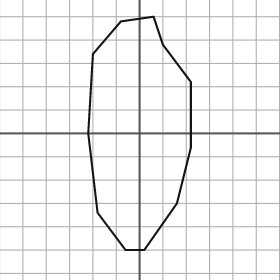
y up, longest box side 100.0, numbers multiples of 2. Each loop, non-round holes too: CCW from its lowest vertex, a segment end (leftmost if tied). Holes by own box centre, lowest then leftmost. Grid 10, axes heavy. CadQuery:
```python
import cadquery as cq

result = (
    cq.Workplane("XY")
    .moveTo(-6.0, -50.0)
    .lineTo(2.0, -50.0)
    .lineTo(16.0, -30.0)
    .lineTo(22.0, -6.0)
    .lineTo(22.0, 22.0)
    .lineTo(10.0, 38.0)
    .lineTo(6.0, 50.0)
    .lineTo(-8.0, 48.0)
    .lineTo(-20.0, 34.0)
    .lineTo(-22.0, 0.0)
    .lineTo(-18.0, -34.0)
    .close()
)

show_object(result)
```